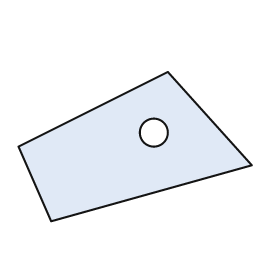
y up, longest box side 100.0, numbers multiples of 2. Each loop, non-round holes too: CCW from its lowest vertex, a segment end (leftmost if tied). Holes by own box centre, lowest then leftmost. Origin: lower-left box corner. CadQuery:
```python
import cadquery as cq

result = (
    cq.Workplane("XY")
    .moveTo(14.0, 0.0)
    .lineTo(100.0, 24.0)
    .lineTo(64.0, 64.0)
    .lineTo(0.0, 32.0)
    .close()
    .moveTo(58.0, 38.0)
    .circle(6.0)
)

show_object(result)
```